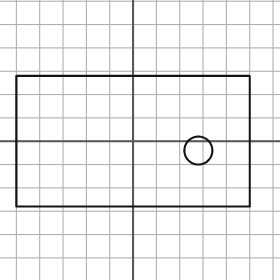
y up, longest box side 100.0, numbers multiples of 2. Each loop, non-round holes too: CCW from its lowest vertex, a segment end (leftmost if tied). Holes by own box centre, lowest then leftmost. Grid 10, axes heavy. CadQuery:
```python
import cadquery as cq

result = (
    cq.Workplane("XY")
    .moveTo(-50.0, -28.0)
    .lineTo(50.0, -28.0)
    .lineTo(50.0, 28.0)
    .lineTo(-50.0, 28.0)
    .close()
    .moveTo(28.0, -4.0)
    .circle(6.0)
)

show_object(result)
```